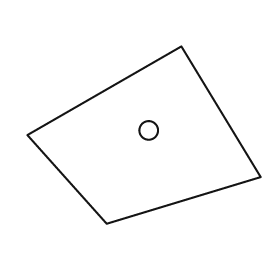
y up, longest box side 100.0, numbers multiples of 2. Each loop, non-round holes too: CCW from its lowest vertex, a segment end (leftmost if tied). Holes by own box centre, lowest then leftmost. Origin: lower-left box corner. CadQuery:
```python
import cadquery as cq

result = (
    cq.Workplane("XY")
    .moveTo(34.0, 0.0)
    .lineTo(100.0, 20.0)
    .lineTo(66.0, 76.0)
    .lineTo(0.0, 38.0)
    .close()
    .moveTo(52.0, 40.0)
    .circle(4.0)
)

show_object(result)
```